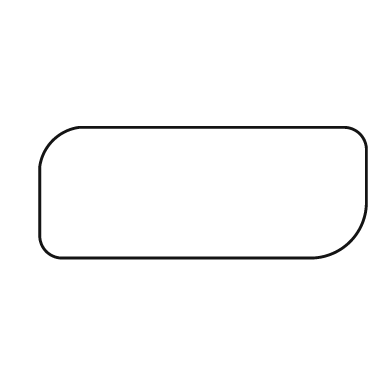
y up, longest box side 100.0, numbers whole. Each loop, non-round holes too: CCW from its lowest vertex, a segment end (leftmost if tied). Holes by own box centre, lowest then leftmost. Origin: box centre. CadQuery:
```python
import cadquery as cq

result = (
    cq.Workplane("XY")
    .moveTo(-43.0, -20.0)
    .lineTo(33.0, -20.0)
    .threePointArc((45.0, -15.0), (50.0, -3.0))
    .lineTo(50.0, 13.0)
    .threePointArc((48.0, 18.0), (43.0, 20.0))
    .lineTo(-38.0, 20.0)
    .threePointArc((-46.0, 16.0), (-50.0, 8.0))
    .lineTo(-50.0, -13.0)
    .threePointArc((-48.0, -18.0), (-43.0, -20.0))
    .close()
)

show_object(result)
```